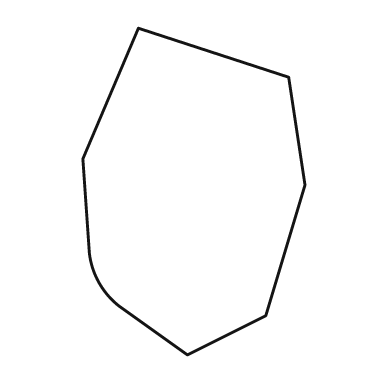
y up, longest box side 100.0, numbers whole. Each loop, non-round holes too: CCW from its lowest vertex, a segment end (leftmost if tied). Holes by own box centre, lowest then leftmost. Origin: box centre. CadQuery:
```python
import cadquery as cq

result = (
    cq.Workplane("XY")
    .moveTo(-2.0, -50.0)
    .lineTo(22.0, -38.0)
    .lineTo(34.0, 2.0)
    .lineTo(29.0, 35.0)
    .lineTo(-17.0, 50.0)
    .lineTo(-34.0, 10.0)
    .lineTo(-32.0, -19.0)
    .threePointArc((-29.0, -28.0), (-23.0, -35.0))
    .close()
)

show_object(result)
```